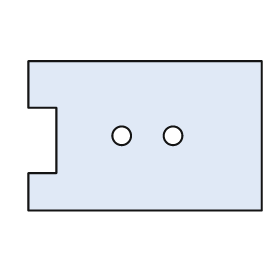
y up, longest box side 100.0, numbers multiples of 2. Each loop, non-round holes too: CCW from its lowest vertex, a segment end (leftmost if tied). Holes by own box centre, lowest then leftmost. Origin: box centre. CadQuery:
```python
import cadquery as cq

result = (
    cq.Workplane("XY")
    .moveTo(-50.0, -32.0)
    .lineTo(50.0, -32.0)
    .lineTo(50.0, 32.0)
    .lineTo(-50.0, 32.0)
    .lineTo(-50.0, 12.0)
    .lineTo(-38.0, 12.0)
    .lineTo(-38.0, -16.0)
    .lineTo(-50.0, -16.0)
    .close()
    .moveTo(-10.0, 0.0)
    .circle(4.0)
    .moveTo(12.0, 0.0)
    .circle(4.0)
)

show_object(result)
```